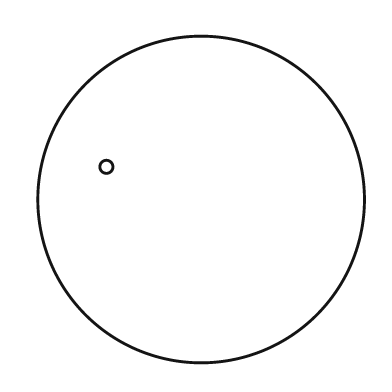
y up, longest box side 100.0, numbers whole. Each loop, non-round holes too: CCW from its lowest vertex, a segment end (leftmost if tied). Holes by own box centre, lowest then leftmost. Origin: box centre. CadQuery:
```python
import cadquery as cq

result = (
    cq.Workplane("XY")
    .moveTo(0.0, 0.0)
    .circle(50.0)
    .moveTo(-29.0, 10.0)
    .circle(2.0)
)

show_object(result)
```